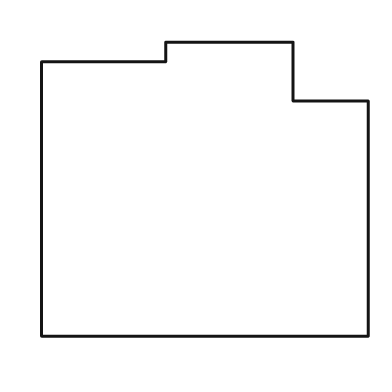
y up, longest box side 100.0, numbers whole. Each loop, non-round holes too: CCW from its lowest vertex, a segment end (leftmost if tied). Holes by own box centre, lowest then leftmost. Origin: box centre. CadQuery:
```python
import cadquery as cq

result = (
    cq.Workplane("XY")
    .moveTo(-50.0, -45.0)
    .lineTo(50.0, -45.0)
    .lineTo(50.0, 27.0)
    .lineTo(27.0, 27.0)
    .lineTo(27.0, 45.0)
    .lineTo(-12.0, 45.0)
    .lineTo(-12.0, 39.0)
    .lineTo(-50.0, 39.0)
    .close()
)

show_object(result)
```